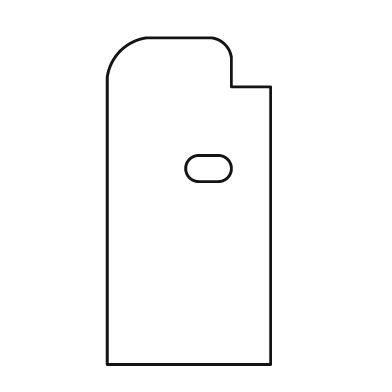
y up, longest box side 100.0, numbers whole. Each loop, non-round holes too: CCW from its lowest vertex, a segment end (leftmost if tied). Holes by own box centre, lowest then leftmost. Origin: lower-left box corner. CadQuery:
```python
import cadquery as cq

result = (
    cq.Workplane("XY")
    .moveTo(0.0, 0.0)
    .lineTo(50.0, 0.0)
    .lineTo(50.0, 85.0)
    .lineTo(38.0, 85.0)
    .lineTo(38.0, 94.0)
    .threePointArc((36.0, 98.0), (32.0, 100.0))
    .lineTo(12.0, 100.0)
    .threePointArc((4.0, 96.0), (0.0, 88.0))
    .close()
    .moveTo(28.0, 56.0)
    .lineTo(34.0, 56.0)
    .threePointArc((38.0, 60.0), (34.0, 64.0))
    .lineTo(28.0, 64.0)
    .threePointArc((24.0, 60.0), (28.0, 56.0))
    .close()
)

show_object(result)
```